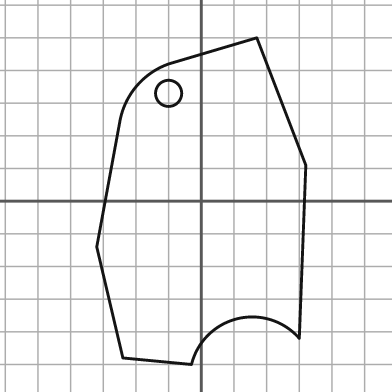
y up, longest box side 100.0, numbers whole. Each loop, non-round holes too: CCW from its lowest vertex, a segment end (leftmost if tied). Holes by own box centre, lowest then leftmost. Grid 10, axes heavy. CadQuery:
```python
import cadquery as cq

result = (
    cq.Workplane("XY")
    .moveTo(-3.0, -50.0)
    .threePointArc((11.0, -36.0), (30.0, -42.0))
    .lineTo(32.0, 11.0)
    .lineTo(17.0, 50.0)
    .lineTo(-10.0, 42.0)
    .threePointArc((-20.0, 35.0), (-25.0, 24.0))
    .lineTo(-32.0, -14.0)
    .lineTo(-24.0, -48.0)
    .close()
    .moveTo(-10.0, 33.0)
    .circle(4.0)
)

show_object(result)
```